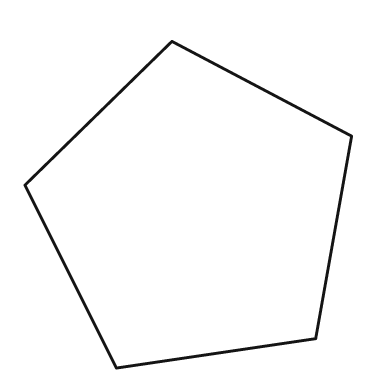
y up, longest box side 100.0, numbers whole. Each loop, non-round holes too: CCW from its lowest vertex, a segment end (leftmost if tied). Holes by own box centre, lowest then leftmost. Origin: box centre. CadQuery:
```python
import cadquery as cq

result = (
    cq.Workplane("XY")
    .moveTo(-22.0, -50.0)
    .lineTo(39.0, -41.0)
    .lineTo(50.0, 21.0)
    .lineTo(-5.0, 50.0)
    .lineTo(-50.0, 6.0)
    .close()
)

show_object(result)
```